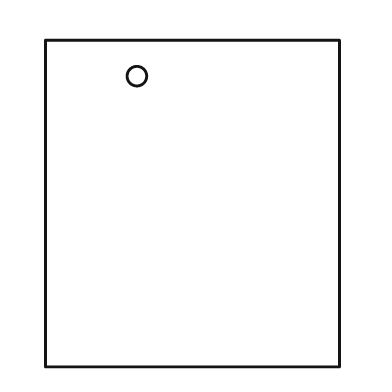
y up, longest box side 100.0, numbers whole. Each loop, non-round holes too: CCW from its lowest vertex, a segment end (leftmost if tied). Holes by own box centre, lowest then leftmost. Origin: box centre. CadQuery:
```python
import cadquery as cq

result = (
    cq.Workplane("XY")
    .moveTo(-45.0, -50.0)
    .lineTo(45.0, -50.0)
    .lineTo(45.0, 50.0)
    .lineTo(-45.0, 50.0)
    .close()
    .moveTo(-17.0, 39.0)
    .circle(3.0)
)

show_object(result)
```